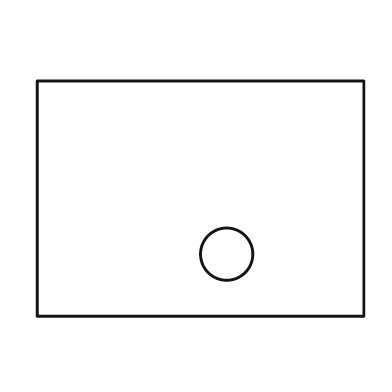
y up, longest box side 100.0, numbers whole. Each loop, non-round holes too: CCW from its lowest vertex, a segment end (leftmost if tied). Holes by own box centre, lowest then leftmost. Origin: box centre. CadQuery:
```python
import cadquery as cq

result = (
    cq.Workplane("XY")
    .moveTo(-50.0, -36.0)
    .lineTo(50.0, -36.0)
    .lineTo(50.0, 36.0)
    .lineTo(-50.0, 36.0)
    .close()
    .moveTo(8.0, -17.0)
    .circle(8.0)
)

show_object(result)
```